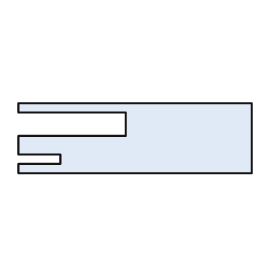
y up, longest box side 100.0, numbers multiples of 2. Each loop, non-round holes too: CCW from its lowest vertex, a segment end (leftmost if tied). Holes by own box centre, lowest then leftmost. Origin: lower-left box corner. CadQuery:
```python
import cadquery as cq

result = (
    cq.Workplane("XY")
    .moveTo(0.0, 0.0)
    .lineTo(100.0, 0.0)
    .lineTo(100.0, 30.0)
    .lineTo(0.0, 30.0)
    .lineTo(0.0, 26.0)
    .lineTo(46.0, 26.0)
    .lineTo(46.0, 16.0)
    .lineTo(0.0, 16.0)
    .lineTo(0.0, 8.0)
    .lineTo(18.0, 8.0)
    .lineTo(18.0, 4.0)
    .lineTo(0.0, 4.0)
    .close()
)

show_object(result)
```